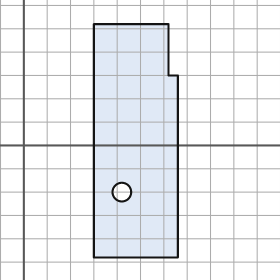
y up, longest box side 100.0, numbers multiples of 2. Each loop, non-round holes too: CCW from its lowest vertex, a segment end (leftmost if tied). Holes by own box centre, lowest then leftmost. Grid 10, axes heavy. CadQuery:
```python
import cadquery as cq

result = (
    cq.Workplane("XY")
    .moveTo(30.0, -48.0)
    .lineTo(66.0, -48.0)
    .lineTo(66.0, 30.0)
    .lineTo(62.0, 30.0)
    .lineTo(62.0, 52.0)
    .lineTo(30.0, 52.0)
    .close()
    .moveTo(42.0, -20.0)
    .circle(4.0)
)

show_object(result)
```